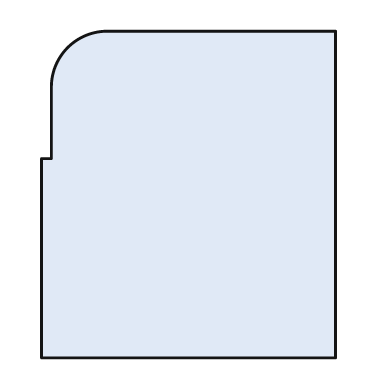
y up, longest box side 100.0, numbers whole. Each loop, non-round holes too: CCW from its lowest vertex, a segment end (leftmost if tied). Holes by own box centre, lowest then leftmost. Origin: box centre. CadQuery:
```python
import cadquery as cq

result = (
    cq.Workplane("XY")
    .moveTo(-45.0, -50.0)
    .lineTo(45.0, -50.0)
    .lineTo(45.0, 50.0)
    .lineTo(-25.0, 50.0)
    .threePointArc((-37.0, 45.0), (-42.0, 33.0))
    .lineTo(-42.0, 11.0)
    .lineTo(-45.0, 11.0)
    .close()
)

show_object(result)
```